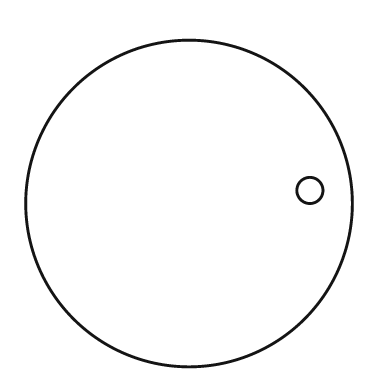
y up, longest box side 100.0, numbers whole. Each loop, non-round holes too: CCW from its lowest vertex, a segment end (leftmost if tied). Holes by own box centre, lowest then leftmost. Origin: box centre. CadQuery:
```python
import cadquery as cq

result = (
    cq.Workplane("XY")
    .moveTo(0.0, 0.0)
    .circle(50.0)
    .moveTo(37.0, 4.0)
    .circle(4.0)
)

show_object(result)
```